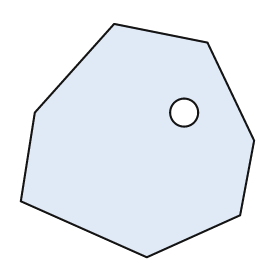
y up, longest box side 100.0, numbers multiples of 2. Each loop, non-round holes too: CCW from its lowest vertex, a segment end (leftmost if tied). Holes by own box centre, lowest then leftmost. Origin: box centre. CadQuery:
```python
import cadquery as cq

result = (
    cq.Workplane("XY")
    .moveTo(4.0, -50.0)
    .lineTo(44.0, -32.0)
    .lineTo(50.0, 0.0)
    .lineTo(30.0, 42.0)
    .lineTo(-10.0, 50.0)
    .lineTo(-44.0, 12.0)
    .lineTo(-50.0, -26.0)
    .close()
    .moveTo(20.0, 12.0)
    .circle(6.0)
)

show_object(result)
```